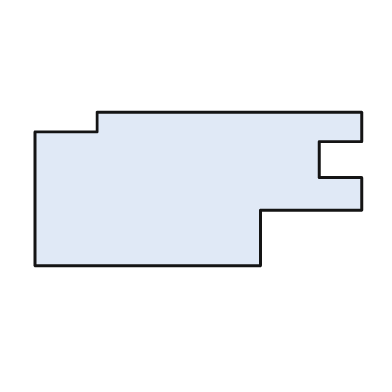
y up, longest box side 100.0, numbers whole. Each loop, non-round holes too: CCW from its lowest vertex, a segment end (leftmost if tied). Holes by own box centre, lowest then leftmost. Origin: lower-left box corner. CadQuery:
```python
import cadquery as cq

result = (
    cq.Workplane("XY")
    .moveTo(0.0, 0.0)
    .lineTo(69.0, 0.0)
    .lineTo(69.0, 17.0)
    .lineTo(100.0, 17.0)
    .lineTo(100.0, 27.0)
    .lineTo(87.0, 27.0)
    .lineTo(87.0, 38.0)
    .lineTo(100.0, 38.0)
    .lineTo(100.0, 47.0)
    .lineTo(19.0, 47.0)
    .lineTo(19.0, 41.0)
    .lineTo(0.0, 41.0)
    .close()
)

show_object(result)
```